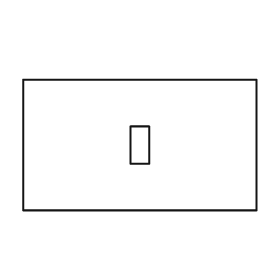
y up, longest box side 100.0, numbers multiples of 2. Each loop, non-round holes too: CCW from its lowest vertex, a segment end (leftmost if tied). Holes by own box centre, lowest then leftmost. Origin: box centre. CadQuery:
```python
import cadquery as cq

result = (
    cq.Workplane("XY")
    .moveTo(-50.0, -28.0)
    .lineTo(50.0, -28.0)
    .lineTo(50.0, 28.0)
    .lineTo(-50.0, 28.0)
    .close()
    .moveTo(-4.0, -8.0)
    .lineTo(4.0, -8.0)
    .lineTo(4.0, 8.0)
    .lineTo(-4.0, 8.0)
    .close()
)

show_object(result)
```